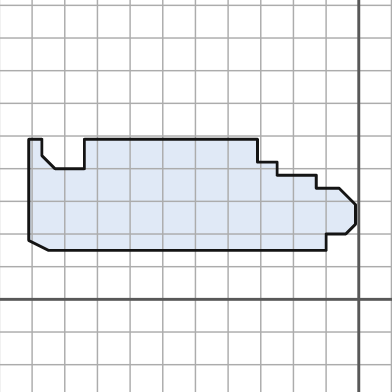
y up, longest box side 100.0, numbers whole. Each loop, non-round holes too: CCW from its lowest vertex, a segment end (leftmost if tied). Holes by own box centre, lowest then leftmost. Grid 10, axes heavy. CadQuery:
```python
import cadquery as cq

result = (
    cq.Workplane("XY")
    .moveTo(-95.0, 15.0)
    .lineTo(-10.0, 15.0)
    .lineTo(-10.0, 20.0)
    .lineTo(-4.0, 20.0)
    .lineTo(-1.0, 23.0)
    .lineTo(-1.0, 29.0)
    .lineTo(-6.0, 34.0)
    .lineTo(-13.0, 34.0)
    .lineTo(-13.0, 38.0)
    .lineTo(-25.0, 38.0)
    .lineTo(-25.0, 42.0)
    .lineTo(-31.0, 42.0)
    .lineTo(-31.0, 49.0)
    .lineTo(-84.0, 49.0)
    .lineTo(-84.0, 40.0)
    .lineTo(-93.0, 40.0)
    .lineTo(-97.0, 44.0)
    .lineTo(-97.0, 49.0)
    .lineTo(-101.0, 49.0)
    .lineTo(-101.0, 18.0)
    .close()
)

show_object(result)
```